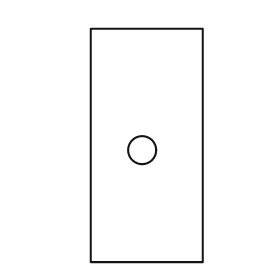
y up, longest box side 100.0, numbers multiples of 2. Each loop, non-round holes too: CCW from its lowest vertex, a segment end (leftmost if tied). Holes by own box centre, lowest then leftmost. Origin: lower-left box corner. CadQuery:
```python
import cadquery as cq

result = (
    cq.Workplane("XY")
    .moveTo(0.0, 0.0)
    .lineTo(48.0, 0.0)
    .lineTo(48.0, 100.0)
    .lineTo(0.0, 100.0)
    .close()
    .moveTo(22.0, 48.0)
    .circle(6.0)
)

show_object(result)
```